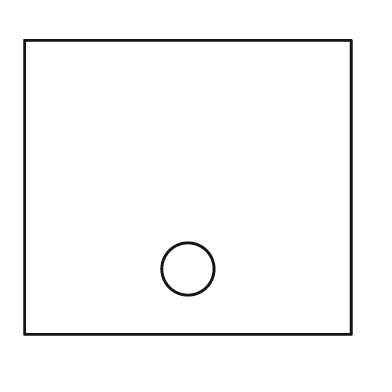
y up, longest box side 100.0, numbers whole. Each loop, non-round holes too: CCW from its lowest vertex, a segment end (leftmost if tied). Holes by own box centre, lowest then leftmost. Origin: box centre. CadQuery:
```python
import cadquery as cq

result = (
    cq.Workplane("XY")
    .moveTo(-50.0, -45.0)
    .lineTo(50.0, -45.0)
    .lineTo(50.0, 45.0)
    .lineTo(-50.0, 45.0)
    .close()
    .moveTo(0.0, -25.0)
    .circle(8.0)
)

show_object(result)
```